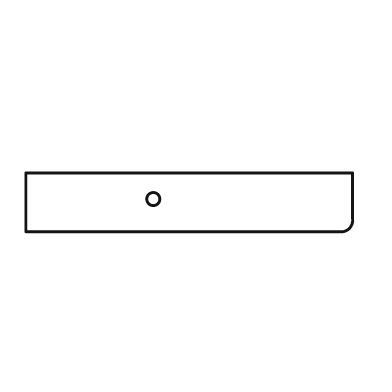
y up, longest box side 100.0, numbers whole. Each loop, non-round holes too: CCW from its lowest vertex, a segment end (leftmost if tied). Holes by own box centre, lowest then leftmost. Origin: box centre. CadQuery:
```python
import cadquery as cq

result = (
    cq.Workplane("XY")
    .moveTo(-50.0, -9.0)
    .lineTo(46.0, -9.0)
    .threePointArc((49.0, -8.0), (50.0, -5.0))
    .lineTo(50.0, 9.0)
    .lineTo(-50.0, 9.0)
    .close()
    .moveTo(-11.0, 1.0)
    .circle(2.0)
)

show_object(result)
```